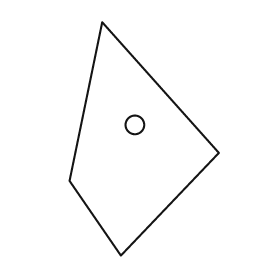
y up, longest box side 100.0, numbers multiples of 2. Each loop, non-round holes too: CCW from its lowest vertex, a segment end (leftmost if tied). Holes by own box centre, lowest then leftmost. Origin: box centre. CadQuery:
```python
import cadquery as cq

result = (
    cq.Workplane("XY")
    .moveTo(-10.0, -50.0)
    .lineTo(32.0, -6.0)
    .lineTo(-18.0, 50.0)
    .lineTo(-32.0, -18.0)
    .close()
    .moveTo(-4.0, 6.0)
    .circle(4.0)
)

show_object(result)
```